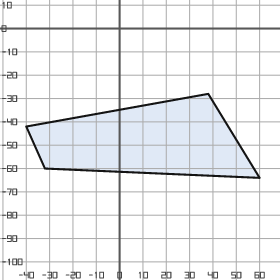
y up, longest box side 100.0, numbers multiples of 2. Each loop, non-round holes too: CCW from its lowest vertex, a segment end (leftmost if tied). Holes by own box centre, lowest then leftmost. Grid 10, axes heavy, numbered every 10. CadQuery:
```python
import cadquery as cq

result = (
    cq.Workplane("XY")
    .moveTo(60.0, -64.0)
    .lineTo(38.0, -28.0)
    .lineTo(-40.0, -42.0)
    .lineTo(-32.0, -60.0)
    .close()
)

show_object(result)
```